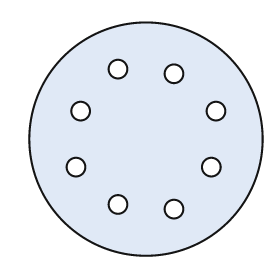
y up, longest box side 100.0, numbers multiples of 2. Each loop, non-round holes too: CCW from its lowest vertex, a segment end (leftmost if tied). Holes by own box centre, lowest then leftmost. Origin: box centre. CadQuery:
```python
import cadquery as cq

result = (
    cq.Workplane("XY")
    .moveTo(0.0, 0.0)
    .circle(50.0)
    .moveTo(12.0, -30.0)
    .circle(4.0)
    .moveTo(-12.0, -28.0)
    .circle(4.0)
    .moveTo(-30.0, -12.0)
    .circle(4.0)
    .moveTo(28.0, -12.0)
    .circle(4.0)
    .moveTo(-28.0, 12.0)
    .circle(4.0)
    .moveTo(30.0, 12.0)
    .circle(4.0)
    .moveTo(12.0, 28.0)
    .circle(4.0)
    .moveTo(-12.0, 30.0)
    .circle(4.0)
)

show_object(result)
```